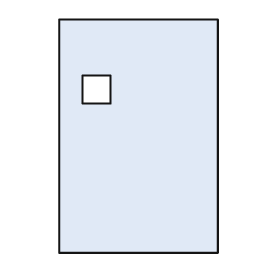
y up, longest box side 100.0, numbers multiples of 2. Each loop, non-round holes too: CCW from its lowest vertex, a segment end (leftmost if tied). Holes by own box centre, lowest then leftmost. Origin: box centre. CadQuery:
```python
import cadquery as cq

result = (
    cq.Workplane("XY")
    .moveTo(-34.0, -50.0)
    .lineTo(34.0, -50.0)
    .lineTo(34.0, 50.0)
    .lineTo(-34.0, 50.0)
    .close()
    .moveTo(-24.0, 14.0)
    .lineTo(-12.0, 14.0)
    .lineTo(-12.0, 26.0)
    .lineTo(-24.0, 26.0)
    .close()
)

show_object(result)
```